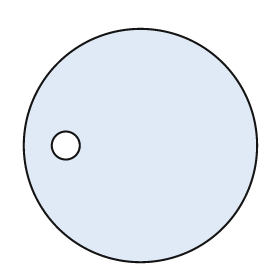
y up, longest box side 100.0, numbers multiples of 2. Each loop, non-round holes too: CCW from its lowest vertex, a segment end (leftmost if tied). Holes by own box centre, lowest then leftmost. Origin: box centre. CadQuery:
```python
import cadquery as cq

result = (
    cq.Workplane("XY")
    .moveTo(0.0, 0.0)
    .circle(50.0)
    .moveTo(-32.0, 0.0)
    .circle(6.0)
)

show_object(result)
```